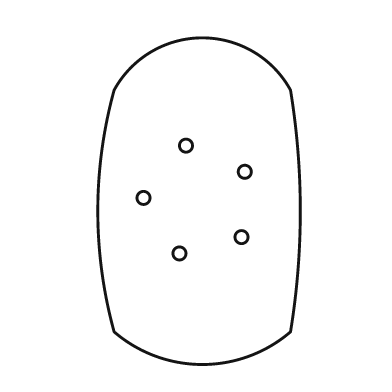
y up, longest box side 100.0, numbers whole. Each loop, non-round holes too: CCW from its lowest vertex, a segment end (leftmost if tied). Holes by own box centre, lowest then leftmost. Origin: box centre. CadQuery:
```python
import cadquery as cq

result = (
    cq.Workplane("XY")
    .moveTo(-26.0, -40.0)
    .threePointArc((1.0, -50.0), (28.0, -40.0))
    .threePointArc((31.0, -3.0), (28.0, 34.0))
    .threePointArc((1.0, 50.0), (-26.0, 34.0))
    .threePointArc((-31.0, -3.0), (-26.0, -40.0))
    .close()
    .moveTo(-6.0, -16.0)
    .circle(2.0)
    .moveTo(13.0, -11.0)
    .circle(2.0)
    .moveTo(-17.0, 1.0)
    .circle(2.0)
    .moveTo(14.0, 9.0)
    .circle(2.0)
    .moveTo(-4.0, 17.0)
    .circle(2.0)
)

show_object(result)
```